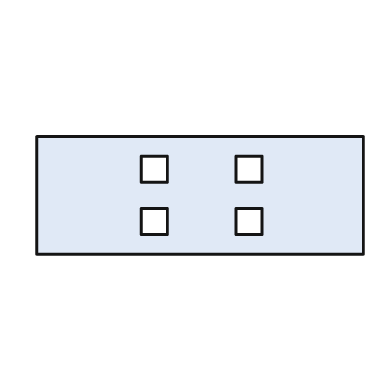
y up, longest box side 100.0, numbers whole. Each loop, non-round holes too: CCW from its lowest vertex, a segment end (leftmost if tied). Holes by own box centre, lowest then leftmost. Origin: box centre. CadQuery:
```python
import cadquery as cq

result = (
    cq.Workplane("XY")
    .moveTo(-50.0, -18.0)
    .lineTo(50.0, -18.0)
    .lineTo(50.0, 18.0)
    .lineTo(-50.0, 18.0)
    .close()
    .moveTo(-18.0, -12.0)
    .lineTo(-10.0, -12.0)
    .lineTo(-10.0, -4.0)
    .lineTo(-18.0, -4.0)
    .close()
    .moveTo(11.0, -12.0)
    .lineTo(19.0, -12.0)
    .lineTo(19.0, -4.0)
    .lineTo(11.0, -4.0)
    .close()
    .moveTo(-18.0, 4.0)
    .lineTo(-10.0, 4.0)
    .lineTo(-10.0, 12.0)
    .lineTo(-18.0, 12.0)
    .close()
    .moveTo(11.0, 4.0)
    .lineTo(19.0, 4.0)
    .lineTo(19.0, 12.0)
    .lineTo(11.0, 12.0)
    .close()
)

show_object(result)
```